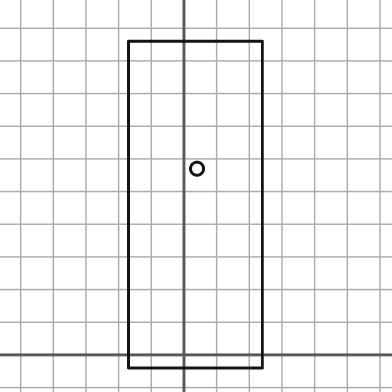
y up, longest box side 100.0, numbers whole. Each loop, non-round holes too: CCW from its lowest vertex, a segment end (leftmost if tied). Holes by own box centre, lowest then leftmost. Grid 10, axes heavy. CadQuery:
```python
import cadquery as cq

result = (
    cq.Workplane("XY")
    .moveTo(-17.0, -4.0)
    .lineTo(24.0, -4.0)
    .lineTo(24.0, 96.0)
    .lineTo(-17.0, 96.0)
    .close()
    .moveTo(4.0, 57.0)
    .circle(2.0)
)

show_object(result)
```